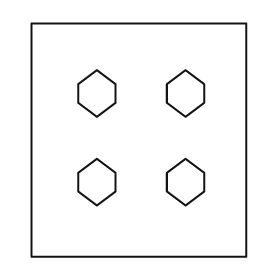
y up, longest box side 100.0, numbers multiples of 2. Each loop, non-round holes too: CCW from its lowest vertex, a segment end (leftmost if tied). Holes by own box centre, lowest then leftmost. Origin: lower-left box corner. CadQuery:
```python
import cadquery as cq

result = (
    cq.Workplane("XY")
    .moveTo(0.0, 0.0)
    .lineTo(92.0, 0.0)
    .lineTo(92.0, 100.0)
    .lineTo(0.0, 100.0)
    .close()
    .moveTo(28.0, 22.0)
    .lineTo(36.0, 28.0)
    .lineTo(36.0, 36.0)
    .lineTo(28.0, 42.0)
    .lineTo(20.0, 36.0)
    .lineTo(20.0, 28.0)
    .close()
    .moveTo(66.0, 22.0)
    .lineTo(74.0, 28.0)
    .lineTo(74.0, 36.0)
    .lineTo(66.0, 42.0)
    .lineTo(58.0, 36.0)
    .lineTo(58.0, 28.0)
    .close()
    .moveTo(28.0, 60.0)
    .lineTo(36.0, 66.0)
    .lineTo(36.0, 74.0)
    .lineTo(28.0, 80.0)
    .lineTo(20.0, 74.0)
    .lineTo(20.0, 66.0)
    .close()
    .moveTo(66.0, 60.0)
    .lineTo(74.0, 66.0)
    .lineTo(74.0, 74.0)
    .lineTo(66.0, 80.0)
    .lineTo(58.0, 74.0)
    .lineTo(58.0, 66.0)
    .close()
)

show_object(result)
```